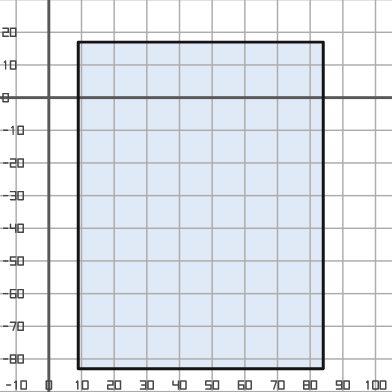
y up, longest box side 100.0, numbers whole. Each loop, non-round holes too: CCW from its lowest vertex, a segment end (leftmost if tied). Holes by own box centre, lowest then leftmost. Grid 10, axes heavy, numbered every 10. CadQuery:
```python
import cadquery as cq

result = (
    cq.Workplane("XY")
    .moveTo(9.0, -83.0)
    .lineTo(84.0, -83.0)
    .lineTo(84.0, 17.0)
    .lineTo(9.0, 17.0)
    .close()
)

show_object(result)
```